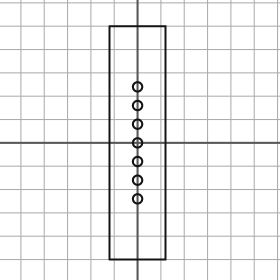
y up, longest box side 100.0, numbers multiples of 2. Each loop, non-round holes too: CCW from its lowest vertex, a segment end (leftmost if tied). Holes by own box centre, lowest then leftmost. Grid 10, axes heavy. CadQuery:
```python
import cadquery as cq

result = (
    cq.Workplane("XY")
    .moveTo(-12.0, -50.0)
    .lineTo(12.0, -50.0)
    .lineTo(12.0, 50.0)
    .lineTo(-12.0, 50.0)
    .close()
    .moveTo(0.0, -24.0)
    .circle(2.0)
    .moveTo(0.0, -16.0)
    .circle(2.0)
    .moveTo(0.0, -8.0)
    .circle(2.0)
    .moveTo(0.0, 0.0)
    .circle(2.0)
    .moveTo(0.0, 8.0)
    .circle(2.0)
    .moveTo(0.0, 16.0)
    .circle(2.0)
    .moveTo(0.0, 24.0)
    .circle(2.0)
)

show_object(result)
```